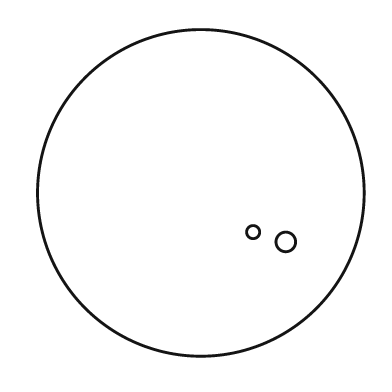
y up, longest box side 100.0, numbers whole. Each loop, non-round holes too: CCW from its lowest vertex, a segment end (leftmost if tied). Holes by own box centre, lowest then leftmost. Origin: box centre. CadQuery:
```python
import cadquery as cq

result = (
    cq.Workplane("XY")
    .moveTo(0.0, 0.0)
    .circle(50.0)
    .moveTo(26.0, -15.0)
    .circle(3.0)
    .moveTo(16.0, -12.0)
    .circle(2.0)
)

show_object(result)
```